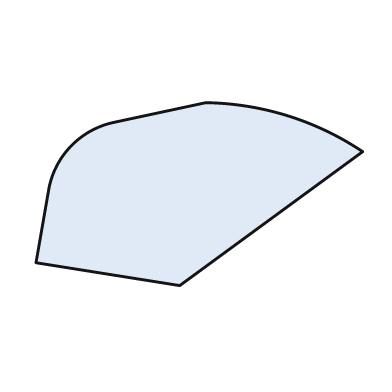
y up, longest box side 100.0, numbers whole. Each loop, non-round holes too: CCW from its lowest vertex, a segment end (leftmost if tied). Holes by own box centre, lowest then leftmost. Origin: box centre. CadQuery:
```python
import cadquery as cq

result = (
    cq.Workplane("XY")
    .moveTo(-6.0, -28.0)
    .lineTo(50.0, 13.0)
    .threePointArc((27.0, 24.0), (2.0, 28.0))
    .lineTo(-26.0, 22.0)
    .threePointArc((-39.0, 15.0), (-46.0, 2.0))
    .lineTo(-50.0, -21.0)
    .close()
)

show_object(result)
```